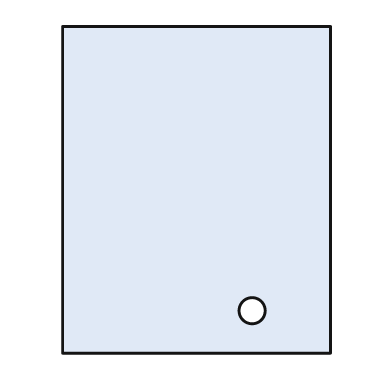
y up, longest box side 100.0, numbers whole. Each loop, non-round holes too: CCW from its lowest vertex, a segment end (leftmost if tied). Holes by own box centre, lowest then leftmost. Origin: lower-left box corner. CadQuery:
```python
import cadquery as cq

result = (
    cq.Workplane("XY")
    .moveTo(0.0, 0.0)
    .lineTo(82.0, 0.0)
    .lineTo(82.0, 100.0)
    .lineTo(0.0, 100.0)
    .close()
    .moveTo(58.0, 13.0)
    .circle(4.0)
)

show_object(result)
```